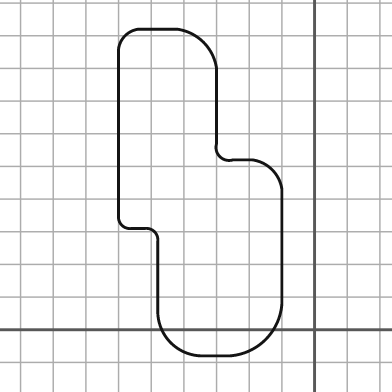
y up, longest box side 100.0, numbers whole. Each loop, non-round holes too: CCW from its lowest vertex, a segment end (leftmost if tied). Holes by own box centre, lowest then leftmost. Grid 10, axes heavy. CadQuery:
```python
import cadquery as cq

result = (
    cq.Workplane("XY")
    .moveTo(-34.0, -8.0)
    .lineTo(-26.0, -8.0)
    .threePointArc((-15.0, -3.0), (-10.0, 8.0))
    .lineTo(-10.0, 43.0)
    .threePointArc((-13.0, 49.0), (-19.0, 52.0))
    .lineTo(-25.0, 52.0)
    .threePointArc((-29.0, 53.0), (-30.0, 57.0))
    .lineTo(-30.0, 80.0)
    .threePointArc((-34.0, 88.0), (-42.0, 92.0))
    .lineTo(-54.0, 92.0)
    .threePointArc((-58.0, 90.0), (-60.0, 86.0))
    .lineTo(-60.0, 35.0)
    .threePointArc((-59.0, 32.0), (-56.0, 31.0))
    .lineTo(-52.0, 31.0)
    .threePointArc((-49.0, 30.0), (-48.0, 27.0))
    .lineTo(-48.0, 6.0)
    .threePointArc((-44.0, -4.0), (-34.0, -8.0))
    .close()
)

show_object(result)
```